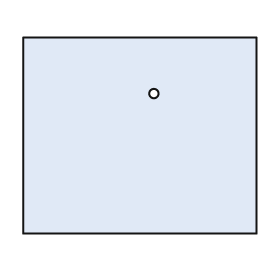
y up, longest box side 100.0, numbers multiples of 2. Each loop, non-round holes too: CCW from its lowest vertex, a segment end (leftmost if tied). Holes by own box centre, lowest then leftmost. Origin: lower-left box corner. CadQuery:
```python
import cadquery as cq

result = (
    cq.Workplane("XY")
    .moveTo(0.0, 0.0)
    .lineTo(100.0, 0.0)
    .lineTo(100.0, 84.0)
    .lineTo(0.0, 84.0)
    .close()
    .moveTo(56.0, 60.0)
    .circle(2.0)
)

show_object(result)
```